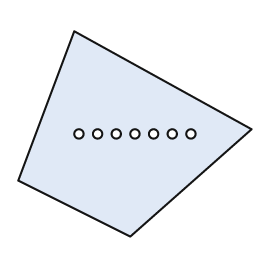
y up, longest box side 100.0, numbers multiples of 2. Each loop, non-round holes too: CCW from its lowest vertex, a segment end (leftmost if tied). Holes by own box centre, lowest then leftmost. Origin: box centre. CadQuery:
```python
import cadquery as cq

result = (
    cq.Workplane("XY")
    .moveTo(-2.0, -44.0)
    .lineTo(50.0, 2.0)
    .lineTo(-26.0, 44.0)
    .lineTo(-50.0, -20.0)
    .close()
    .moveTo(-24.0, 0.0)
    .circle(2.0)
    .moveTo(-16.0, 0.0)
    .circle(2.0)
    .moveTo(-8.0, 0.0)
    .circle(2.0)
    .moveTo(0.0, 0.0)
    .circle(2.0)
    .moveTo(8.0, 0.0)
    .circle(2.0)
    .moveTo(16.0, 0.0)
    .circle(2.0)
    .moveTo(24.0, 0.0)
    .circle(2.0)
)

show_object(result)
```